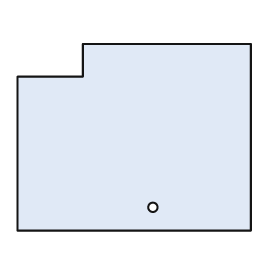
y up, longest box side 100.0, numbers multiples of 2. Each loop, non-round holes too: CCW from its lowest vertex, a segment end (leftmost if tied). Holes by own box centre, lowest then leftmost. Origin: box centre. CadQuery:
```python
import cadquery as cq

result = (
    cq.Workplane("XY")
    .moveTo(-50.0, -40.0)
    .lineTo(50.0, -40.0)
    .lineTo(50.0, 40.0)
    .lineTo(-22.0, 40.0)
    .lineTo(-22.0, 26.0)
    .lineTo(-50.0, 26.0)
    .close()
    .moveTo(8.0, -30.0)
    .circle(2.0)
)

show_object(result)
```